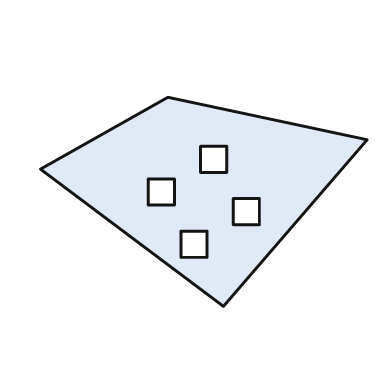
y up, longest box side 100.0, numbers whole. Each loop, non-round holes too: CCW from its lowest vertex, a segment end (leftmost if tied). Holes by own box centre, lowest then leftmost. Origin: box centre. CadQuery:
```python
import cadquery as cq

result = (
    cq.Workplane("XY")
    .moveTo(6.0, -32.0)
    .lineTo(50.0, 19.0)
    .lineTo(-11.0, 32.0)
    .lineTo(-50.0, 10.0)
    .close()
    .moveTo(-7.0, -17.0)
    .lineTo(1.0, -17.0)
    .lineTo(1.0, -9.0)
    .lineTo(-7.0, -9.0)
    .close()
    .moveTo(9.0, -7.0)
    .lineTo(17.0, -7.0)
    .lineTo(17.0, 1.0)
    .lineTo(9.0, 1.0)
    .close()
    .moveTo(-17.0, -1.0)
    .lineTo(-9.0, -1.0)
    .lineTo(-9.0, 7.0)
    .lineTo(-17.0, 7.0)
    .close()
    .moveTo(-1.0, 9.0)
    .lineTo(7.0, 9.0)
    .lineTo(7.0, 17.0)
    .lineTo(-1.0, 17.0)
    .close()
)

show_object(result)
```